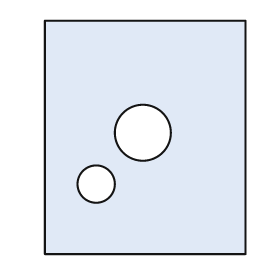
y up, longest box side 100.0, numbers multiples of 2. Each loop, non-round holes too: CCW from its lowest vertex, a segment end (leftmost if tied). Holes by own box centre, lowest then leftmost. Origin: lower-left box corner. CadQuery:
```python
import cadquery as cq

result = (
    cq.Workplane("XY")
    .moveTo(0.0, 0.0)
    .lineTo(86.0, 0.0)
    .lineTo(86.0, 100.0)
    .lineTo(0.0, 100.0)
    .close()
    .moveTo(22.0, 30.0)
    .circle(8.0)
    .moveTo(42.0, 52.0)
    .circle(12.0)
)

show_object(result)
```